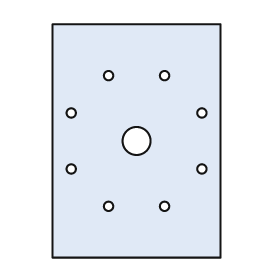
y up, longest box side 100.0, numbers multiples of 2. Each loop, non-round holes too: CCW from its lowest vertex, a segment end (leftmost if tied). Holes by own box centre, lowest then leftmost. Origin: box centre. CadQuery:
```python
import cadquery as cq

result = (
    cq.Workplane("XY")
    .moveTo(-36.0, -50.0)
    .lineTo(36.0, -50.0)
    .lineTo(36.0, 50.0)
    .lineTo(-36.0, 50.0)
    .close()
    .moveTo(-12.0, -28.0)
    .circle(2.0)
    .moveTo(12.0, -28.0)
    .circle(2.0)
    .moveTo(-28.0, -12.0)
    .circle(2.0)
    .moveTo(28.0, -12.0)
    .circle(2.0)
    .moveTo(0.0, 0.0)
    .circle(6.0)
    .moveTo(-28.0, 12.0)
    .circle(2.0)
    .moveTo(28.0, 12.0)
    .circle(2.0)
    .moveTo(-12.0, 28.0)
    .circle(2.0)
    .moveTo(12.0, 28.0)
    .circle(2.0)
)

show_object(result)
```